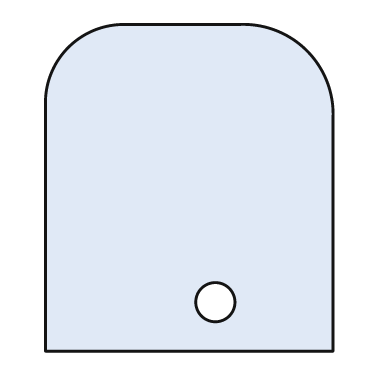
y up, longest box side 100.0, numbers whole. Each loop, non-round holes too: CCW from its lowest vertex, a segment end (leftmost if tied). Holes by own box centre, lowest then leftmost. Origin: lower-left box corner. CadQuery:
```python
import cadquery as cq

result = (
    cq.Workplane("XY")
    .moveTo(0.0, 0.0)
    .lineTo(88.0, 0.0)
    .lineTo(88.0, 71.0)
    .threePointArc((80.0, 92.0), (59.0, 100.0))
    .lineTo(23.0, 100.0)
    .threePointArc((7.0, 93.0), (0.0, 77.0))
    .close()
    .moveTo(52.0, 15.0)
    .circle(6.0)
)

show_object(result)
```